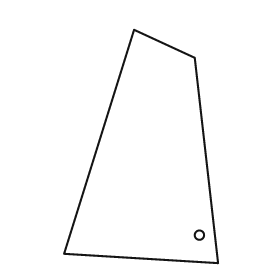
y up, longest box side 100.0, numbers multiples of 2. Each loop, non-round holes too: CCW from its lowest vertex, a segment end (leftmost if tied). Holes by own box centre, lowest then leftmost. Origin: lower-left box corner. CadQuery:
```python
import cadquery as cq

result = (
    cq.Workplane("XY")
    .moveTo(66.0, 0.0)
    .lineTo(56.0, 88.0)
    .lineTo(30.0, 100.0)
    .lineTo(0.0, 4.0)
    .close()
    .moveTo(58.0, 12.0)
    .circle(2.0)
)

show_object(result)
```